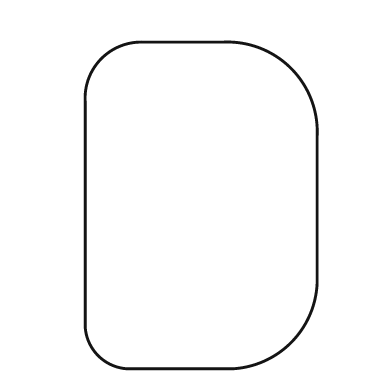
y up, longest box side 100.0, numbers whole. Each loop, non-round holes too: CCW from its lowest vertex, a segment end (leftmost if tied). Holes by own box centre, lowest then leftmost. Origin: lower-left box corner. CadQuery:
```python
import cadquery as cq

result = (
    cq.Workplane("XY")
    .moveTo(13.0, 0.0)
    .lineTo(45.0, 0.0)
    .threePointArc((63.0, 8.0), (71.0, 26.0))
    .lineTo(71.0, 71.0)
    .threePointArc((63.0, 92.0), (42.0, 100.0))
    .lineTo(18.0, 100.0)
    .threePointArc((5.0, 95.0), (0.0, 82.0))
    .lineTo(0.0, 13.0)
    .threePointArc((4.0, 4.0), (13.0, 0.0))
    .close()
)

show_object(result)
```